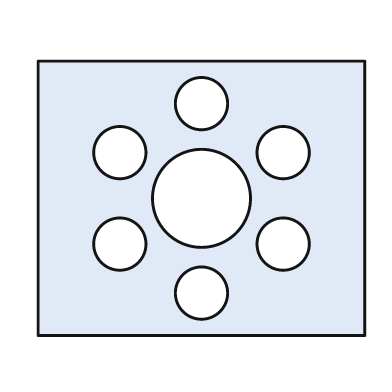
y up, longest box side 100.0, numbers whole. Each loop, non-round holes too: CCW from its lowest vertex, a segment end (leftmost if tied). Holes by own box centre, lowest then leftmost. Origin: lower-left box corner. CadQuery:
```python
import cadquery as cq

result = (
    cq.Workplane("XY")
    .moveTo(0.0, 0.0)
    .lineTo(100.0, 0.0)
    .lineTo(100.0, 84.0)
    .lineTo(0.0, 84.0)
    .close()
    .moveTo(50.0, 13.0)
    .circle(8.0)
    .moveTo(25.0, 28.0)
    .circle(8.0)
    .moveTo(75.0, 28.0)
    .circle(8.0)
    .moveTo(50.0, 42.0)
    .circle(15.0)
    .moveTo(25.0, 56.0)
    .circle(8.0)
    .moveTo(75.0, 56.0)
    .circle(8.0)
    .moveTo(50.0, 71.0)
    .circle(8.0)
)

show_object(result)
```